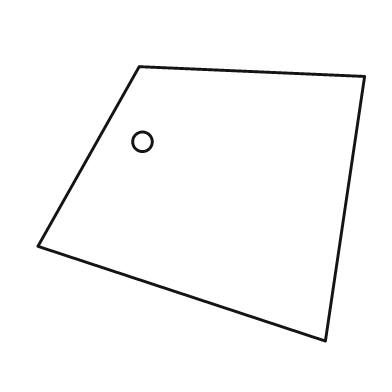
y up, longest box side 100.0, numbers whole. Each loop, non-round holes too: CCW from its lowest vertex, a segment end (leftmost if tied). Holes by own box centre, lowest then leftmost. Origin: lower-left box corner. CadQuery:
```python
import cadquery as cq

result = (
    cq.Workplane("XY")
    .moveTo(88.0, 0.0)
    .lineTo(100.0, 81.0)
    .lineTo(31.0, 84.0)
    .lineTo(0.0, 29.0)
    .close()
    .moveTo(32.0, 61.0)
    .circle(3.0)
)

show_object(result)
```